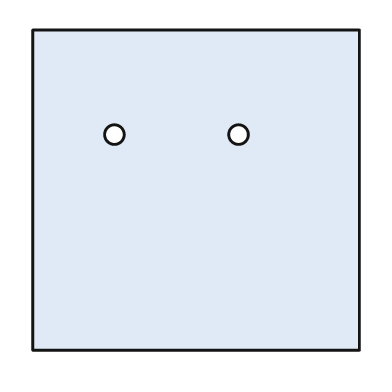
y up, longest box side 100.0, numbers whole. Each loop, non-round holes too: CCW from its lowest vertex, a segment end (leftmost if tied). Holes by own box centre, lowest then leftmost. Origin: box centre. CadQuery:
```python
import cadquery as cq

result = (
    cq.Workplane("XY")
    .moveTo(-50.0, -49.0)
    .lineTo(50.0, -49.0)
    .lineTo(50.0, 49.0)
    .lineTo(-50.0, 49.0)
    .close()
    .moveTo(-25.0, 17.0)
    .circle(3.0)
    .moveTo(13.0, 17.0)
    .circle(3.0)
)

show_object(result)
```